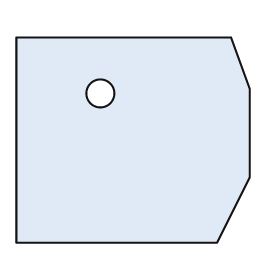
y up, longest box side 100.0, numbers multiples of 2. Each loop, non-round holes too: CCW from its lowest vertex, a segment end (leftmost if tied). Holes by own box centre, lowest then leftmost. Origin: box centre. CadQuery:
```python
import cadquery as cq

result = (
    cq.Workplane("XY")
    .moveTo(-50.0, -44.0)
    .lineTo(36.0, -44.0)
    .lineTo(50.0, -16.0)
    .lineTo(50.0, 22.0)
    .lineTo(42.0, 44.0)
    .lineTo(-50.0, 44.0)
    .close()
    .moveTo(-14.0, 20.0)
    .circle(6.0)
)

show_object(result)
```